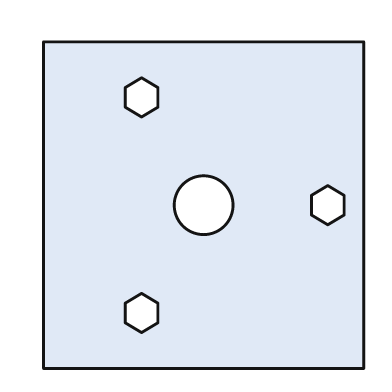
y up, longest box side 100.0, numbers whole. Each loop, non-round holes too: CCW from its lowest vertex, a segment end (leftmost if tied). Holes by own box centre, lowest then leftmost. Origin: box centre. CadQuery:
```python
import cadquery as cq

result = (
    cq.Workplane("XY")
    .moveTo(-49.0, -50.0)
    .lineTo(49.0, -50.0)
    .lineTo(49.0, 50.0)
    .lineTo(-49.0, 50.0)
    .close()
    .moveTo(-19.0, -39.0)
    .lineTo(-14.0, -36.0)
    .lineTo(-14.0, -30.0)
    .lineTo(-19.0, -27.0)
    .lineTo(-24.0, -30.0)
    .lineTo(-24.0, -36.0)
    .close()
    .moveTo(0.0, 0.0)
    .circle(9.0)
    .moveTo(38.0, -6.0)
    .lineTo(43.0, -3.0)
    .lineTo(43.0, 3.0)
    .lineTo(38.0, 6.0)
    .lineTo(33.0, 3.0)
    .lineTo(33.0, -3.0)
    .close()
    .moveTo(-19.0, 27.0)
    .lineTo(-14.0, 30.0)
    .lineTo(-14.0, 36.0)
    .lineTo(-19.0, 39.0)
    .lineTo(-24.0, 36.0)
    .lineTo(-24.0, 30.0)
    .close()
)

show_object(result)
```